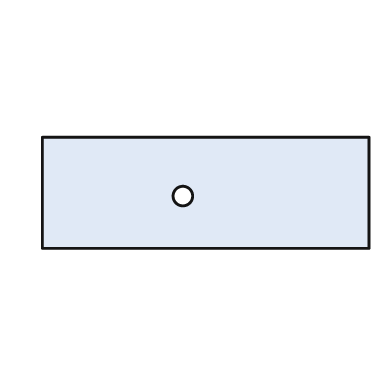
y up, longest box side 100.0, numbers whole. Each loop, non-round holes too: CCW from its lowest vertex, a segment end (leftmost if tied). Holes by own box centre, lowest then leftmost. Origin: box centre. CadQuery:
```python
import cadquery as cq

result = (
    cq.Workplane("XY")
    .moveTo(-50.0, -17.0)
    .lineTo(50.0, -17.0)
    .lineTo(50.0, 17.0)
    .lineTo(-50.0, 17.0)
    .close()
    .moveTo(-7.0, -1.0)
    .circle(3.0)
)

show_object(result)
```